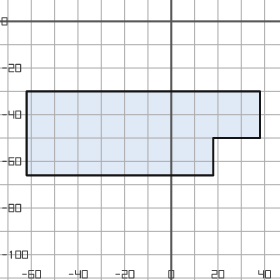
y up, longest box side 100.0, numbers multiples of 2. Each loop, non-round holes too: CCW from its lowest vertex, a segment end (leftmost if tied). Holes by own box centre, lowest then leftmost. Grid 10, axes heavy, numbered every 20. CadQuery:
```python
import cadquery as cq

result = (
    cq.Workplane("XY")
    .moveTo(-62.0, -66.0)
    .lineTo(18.0, -66.0)
    .lineTo(18.0, -50.0)
    .lineTo(38.0, -50.0)
    .lineTo(38.0, -30.0)
    .lineTo(-62.0, -30.0)
    .close()
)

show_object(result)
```